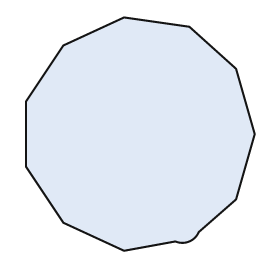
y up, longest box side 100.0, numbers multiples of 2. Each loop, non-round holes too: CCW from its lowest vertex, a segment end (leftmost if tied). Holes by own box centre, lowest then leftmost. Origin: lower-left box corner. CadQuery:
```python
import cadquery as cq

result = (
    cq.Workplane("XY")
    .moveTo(42.0, 0.0)
    .lineTo(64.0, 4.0)
    .threePointArc((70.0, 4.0), (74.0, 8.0))
    .lineTo(90.0, 22.0)
    .lineTo(98.0, 50.0)
    .lineTo(90.0, 78.0)
    .lineTo(70.0, 96.0)
    .lineTo(42.0, 100.0)
    .lineTo(16.0, 88.0)
    .lineTo(0.0, 64.0)
    .lineTo(0.0, 36.0)
    .lineTo(16.0, 12.0)
    .close()
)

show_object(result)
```